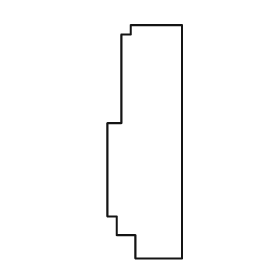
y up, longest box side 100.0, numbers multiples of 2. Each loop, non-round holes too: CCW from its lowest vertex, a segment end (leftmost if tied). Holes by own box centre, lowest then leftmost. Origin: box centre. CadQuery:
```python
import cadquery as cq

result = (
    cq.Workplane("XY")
    .moveTo(-4.0, -50.0)
    .lineTo(16.0, -50.0)
    .lineTo(16.0, 50.0)
    .lineTo(-6.0, 50.0)
    .lineTo(-6.0, 46.0)
    .lineTo(-10.0, 46.0)
    .lineTo(-10.0, 8.0)
    .lineTo(-16.0, 8.0)
    .lineTo(-16.0, -32.0)
    .lineTo(-12.0, -32.0)
    .lineTo(-12.0, -40.0)
    .lineTo(-4.0, -40.0)
    .close()
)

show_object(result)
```